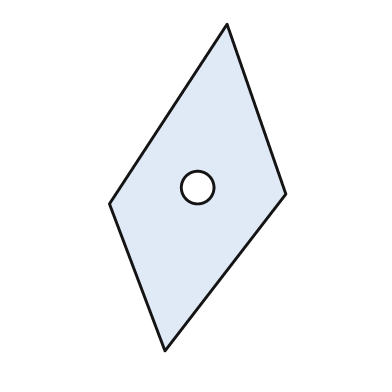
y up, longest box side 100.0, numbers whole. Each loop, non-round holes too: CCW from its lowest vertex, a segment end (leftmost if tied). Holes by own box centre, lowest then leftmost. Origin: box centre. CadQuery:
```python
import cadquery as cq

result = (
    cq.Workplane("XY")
    .moveTo(-10.0, -50.0)
    .lineTo(27.0, -2.0)
    .lineTo(9.0, 50.0)
    .lineTo(-27.0, -5.0)
    .close()
    .moveTo(0.0, 0.0)
    .circle(5.0)
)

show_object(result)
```